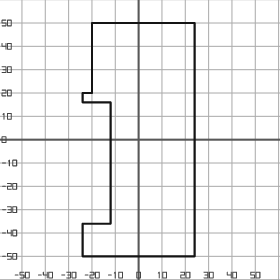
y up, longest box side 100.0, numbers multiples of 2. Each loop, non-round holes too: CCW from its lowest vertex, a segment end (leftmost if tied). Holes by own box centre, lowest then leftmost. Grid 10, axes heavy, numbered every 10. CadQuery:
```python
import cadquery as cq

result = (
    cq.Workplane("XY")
    .moveTo(-24.0, -50.0)
    .lineTo(24.0, -50.0)
    .lineTo(24.0, 50.0)
    .lineTo(-20.0, 50.0)
    .lineTo(-20.0, 20.0)
    .lineTo(-24.0, 20.0)
    .lineTo(-24.0, 16.0)
    .lineTo(-12.0, 16.0)
    .lineTo(-12.0, -36.0)
    .lineTo(-24.0, -36.0)
    .close()
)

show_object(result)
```